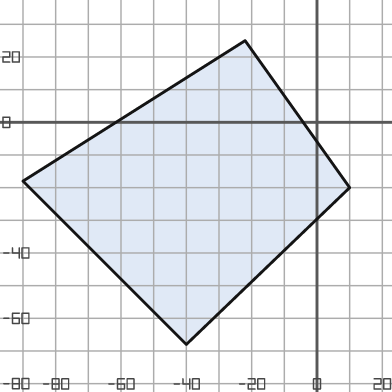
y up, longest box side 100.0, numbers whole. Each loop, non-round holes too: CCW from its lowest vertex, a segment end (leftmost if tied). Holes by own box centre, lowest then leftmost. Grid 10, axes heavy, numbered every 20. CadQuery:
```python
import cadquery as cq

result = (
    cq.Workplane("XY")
    .moveTo(-40.0, -68.0)
    .lineTo(10.0, -20.0)
    .lineTo(-22.0, 25.0)
    .lineTo(-90.0, -18.0)
    .close()
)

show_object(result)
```